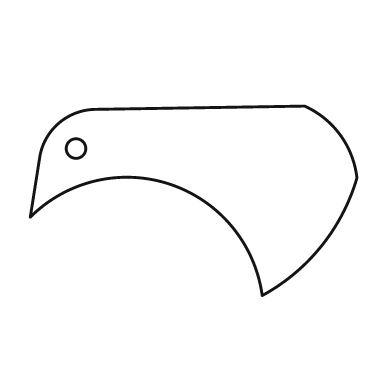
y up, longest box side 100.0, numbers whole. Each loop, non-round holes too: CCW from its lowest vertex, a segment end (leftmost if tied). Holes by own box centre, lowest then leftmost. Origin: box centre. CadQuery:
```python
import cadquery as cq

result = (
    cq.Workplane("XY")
    .moveTo(21.0, -29.0)
    .threePointArc((39.0, -14.0), (50.0, 7.0))
    .threePointArc((45.0, 20.0), (34.0, 29.0))
    .lineTo(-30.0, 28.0)
    .threePointArc((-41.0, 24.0), (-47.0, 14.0))
    .lineTo(-50.0, -5.0)
    .threePointArc((-7.0, 5.0), (21.0, -29.0))
    .close()
    .moveTo(-36.0, 16.0)
    .circle(3.0)
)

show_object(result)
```